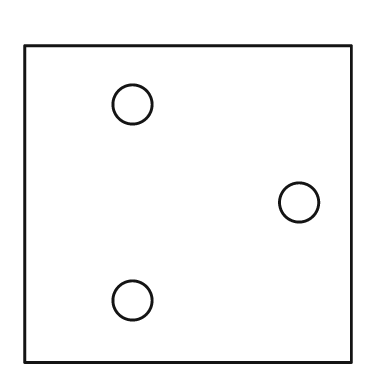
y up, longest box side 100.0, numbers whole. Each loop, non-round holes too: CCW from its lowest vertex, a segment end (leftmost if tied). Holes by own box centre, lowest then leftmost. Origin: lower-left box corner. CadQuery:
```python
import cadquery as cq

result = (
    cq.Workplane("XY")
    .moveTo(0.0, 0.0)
    .lineTo(100.0, 0.0)
    .lineTo(100.0, 97.0)
    .lineTo(0.0, 97.0)
    .close()
    .moveTo(33.0, 19.0)
    .circle(6.0)
    .moveTo(84.0, 49.0)
    .circle(6.0)
    .moveTo(33.0, 79.0)
    .circle(6.0)
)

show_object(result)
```